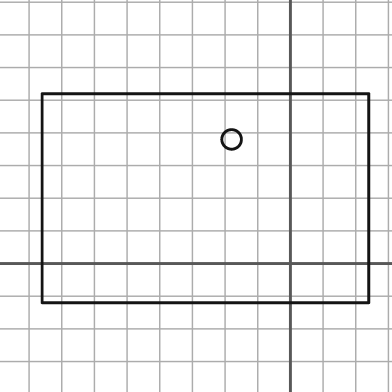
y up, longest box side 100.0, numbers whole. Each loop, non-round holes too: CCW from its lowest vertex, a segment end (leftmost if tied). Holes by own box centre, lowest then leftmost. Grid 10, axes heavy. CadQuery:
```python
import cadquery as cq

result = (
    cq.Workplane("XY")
    .moveTo(-76.0, -12.0)
    .lineTo(24.0, -12.0)
    .lineTo(24.0, 52.0)
    .lineTo(-76.0, 52.0)
    .close()
    .moveTo(-18.0, 38.0)
    .circle(3.0)
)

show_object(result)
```